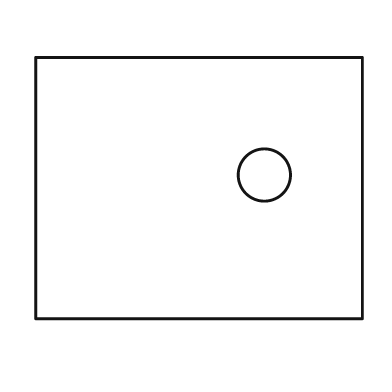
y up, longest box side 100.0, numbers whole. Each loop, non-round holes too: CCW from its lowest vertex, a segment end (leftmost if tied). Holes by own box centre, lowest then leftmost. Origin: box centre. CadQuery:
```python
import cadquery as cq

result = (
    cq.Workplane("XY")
    .moveTo(-50.0, -40.0)
    .lineTo(50.0, -40.0)
    .lineTo(50.0, 40.0)
    .lineTo(-50.0, 40.0)
    .close()
    .moveTo(20.0, 4.0)
    .circle(8.0)
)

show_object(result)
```